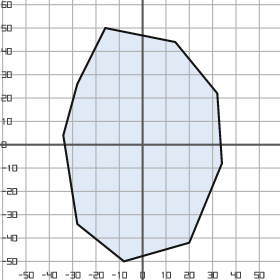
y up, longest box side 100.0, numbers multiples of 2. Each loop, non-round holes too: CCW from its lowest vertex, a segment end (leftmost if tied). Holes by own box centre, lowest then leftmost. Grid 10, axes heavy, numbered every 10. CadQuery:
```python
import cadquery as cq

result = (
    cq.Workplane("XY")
    .moveTo(-8.0, -50.0)
    .lineTo(20.0, -42.0)
    .lineTo(34.0, -8.0)
    .lineTo(32.0, 22.0)
    .lineTo(14.0, 44.0)
    .lineTo(-16.0, 50.0)
    .lineTo(-28.0, 26.0)
    .lineTo(-34.0, 4.0)
    .lineTo(-28.0, -34.0)
    .close()
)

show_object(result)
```